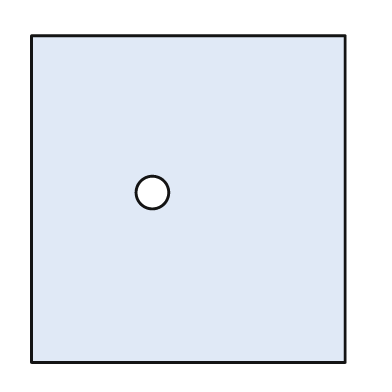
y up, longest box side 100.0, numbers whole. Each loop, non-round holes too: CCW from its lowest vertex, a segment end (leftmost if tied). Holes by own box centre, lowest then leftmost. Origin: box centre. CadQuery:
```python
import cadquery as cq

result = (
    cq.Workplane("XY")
    .moveTo(-48.0, -50.0)
    .lineTo(48.0, -50.0)
    .lineTo(48.0, 50.0)
    .lineTo(-48.0, 50.0)
    .close()
    .moveTo(-11.0, 2.0)
    .circle(5.0)
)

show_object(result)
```